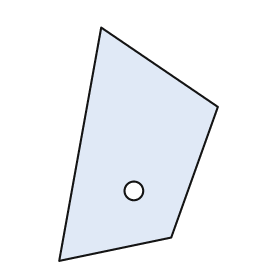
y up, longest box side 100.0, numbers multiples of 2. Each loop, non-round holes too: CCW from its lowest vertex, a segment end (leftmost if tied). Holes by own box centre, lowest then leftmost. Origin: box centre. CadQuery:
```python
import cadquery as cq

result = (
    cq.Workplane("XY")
    .moveTo(-34.0, -50.0)
    .lineTo(14.0, -40.0)
    .lineTo(34.0, 16.0)
    .lineTo(-16.0, 50.0)
    .close()
    .moveTo(-2.0, -20.0)
    .circle(4.0)
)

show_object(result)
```